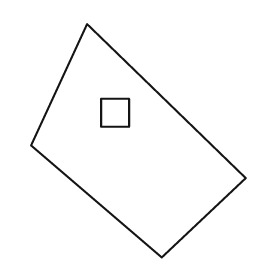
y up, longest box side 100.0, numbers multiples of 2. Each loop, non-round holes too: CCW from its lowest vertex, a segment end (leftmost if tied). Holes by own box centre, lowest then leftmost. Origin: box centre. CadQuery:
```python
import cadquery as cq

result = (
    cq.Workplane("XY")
    .moveTo(10.0, -50.0)
    .lineTo(46.0, -16.0)
    .lineTo(-22.0, 50.0)
    .lineTo(-46.0, -2.0)
    .close()
    .moveTo(-16.0, 6.0)
    .lineTo(-4.0, 6.0)
    .lineTo(-4.0, 18.0)
    .lineTo(-16.0, 18.0)
    .close()
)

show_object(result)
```